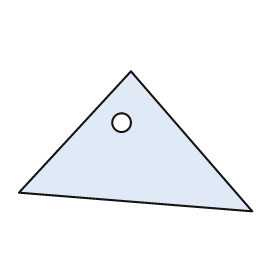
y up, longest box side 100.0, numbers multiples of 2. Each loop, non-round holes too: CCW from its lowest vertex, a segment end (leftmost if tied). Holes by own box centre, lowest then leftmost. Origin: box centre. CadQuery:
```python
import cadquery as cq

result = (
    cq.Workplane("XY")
    .moveTo(50.0, -30.0)
    .lineTo(-2.0, 30.0)
    .lineTo(-50.0, -22.0)
    .close()
    .moveTo(-6.0, 8.0)
    .circle(4.0)
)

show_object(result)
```